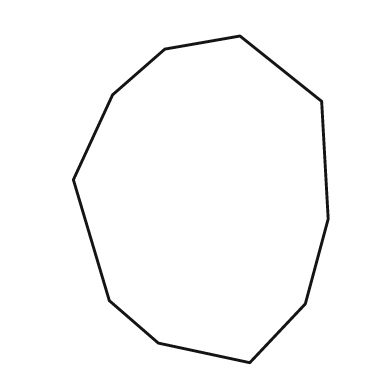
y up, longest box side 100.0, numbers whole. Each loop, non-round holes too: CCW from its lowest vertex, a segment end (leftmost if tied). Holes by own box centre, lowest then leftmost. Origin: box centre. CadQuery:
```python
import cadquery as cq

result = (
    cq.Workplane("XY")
    .moveTo(15.0, -50.0)
    .lineTo(32.0, -32.0)
    .lineTo(39.0, -6.0)
    .lineTo(37.0, 30.0)
    .lineTo(12.0, 50.0)
    .lineTo(-11.0, 46.0)
    .lineTo(-27.0, 32.0)
    .lineTo(-39.0, 6.0)
    .lineTo(-28.0, -31.0)
    .lineTo(-13.0, -44.0)
    .close()
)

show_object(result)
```